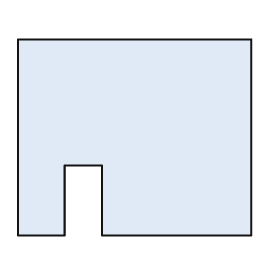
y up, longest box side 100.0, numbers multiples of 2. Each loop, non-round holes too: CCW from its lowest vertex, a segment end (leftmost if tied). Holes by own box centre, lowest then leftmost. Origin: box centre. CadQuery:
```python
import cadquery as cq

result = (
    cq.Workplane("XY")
    .moveTo(-50.0, -42.0)
    .lineTo(-30.0, -42.0)
    .lineTo(-30.0, -12.0)
    .lineTo(-14.0, -12.0)
    .lineTo(-14.0, -42.0)
    .lineTo(50.0, -42.0)
    .lineTo(50.0, 42.0)
    .lineTo(-50.0, 42.0)
    .close()
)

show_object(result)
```